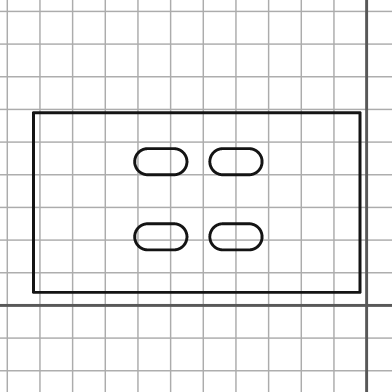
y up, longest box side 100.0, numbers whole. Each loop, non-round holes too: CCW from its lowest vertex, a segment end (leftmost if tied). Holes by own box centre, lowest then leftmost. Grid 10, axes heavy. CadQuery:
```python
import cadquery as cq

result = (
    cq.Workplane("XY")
    .moveTo(-102.0, 4.0)
    .lineTo(-2.0, 4.0)
    .lineTo(-2.0, 59.0)
    .lineTo(-102.0, 59.0)
    .close()
    .moveTo(-67.0, 17.0)
    .lineTo(-59.0, 17.0)
    .threePointArc((-55.0, 21.0), (-59.0, 25.0))
    .lineTo(-67.0, 25.0)
    .threePointArc((-71.0, 21.0), (-67.0, 17.0))
    .close()
    .moveTo(-44.0, 17.0)
    .lineTo(-36.0, 17.0)
    .threePointArc((-32.0, 21.0), (-36.0, 25.0))
    .lineTo(-44.0, 25.0)
    .threePointArc((-48.0, 21.0), (-44.0, 17.0))
    .close()
    .moveTo(-67.0, 40.0)
    .lineTo(-59.0, 40.0)
    .threePointArc((-55.0, 44.0), (-59.0, 48.0))
    .lineTo(-67.0, 48.0)
    .threePointArc((-71.0, 44.0), (-67.0, 40.0))
    .close()
    .moveTo(-44.0, 40.0)
    .lineTo(-36.0, 40.0)
    .threePointArc((-32.0, 44.0), (-36.0, 48.0))
    .lineTo(-44.0, 48.0)
    .threePointArc((-48.0, 44.0), (-44.0, 40.0))
    .close()
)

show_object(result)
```